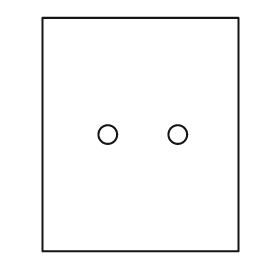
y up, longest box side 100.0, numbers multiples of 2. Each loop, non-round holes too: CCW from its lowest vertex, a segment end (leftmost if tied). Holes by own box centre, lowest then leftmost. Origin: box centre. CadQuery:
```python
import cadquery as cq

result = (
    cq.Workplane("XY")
    .moveTo(-42.0, -50.0)
    .lineTo(42.0, -50.0)
    .lineTo(42.0, 50.0)
    .lineTo(-42.0, 50.0)
    .close()
    .moveTo(-14.0, 0.0)
    .circle(4.0)
    .moveTo(16.0, 0.0)
    .circle(4.0)
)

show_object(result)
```